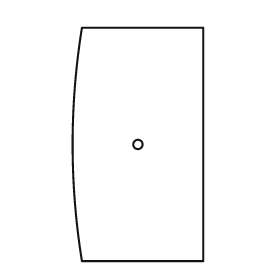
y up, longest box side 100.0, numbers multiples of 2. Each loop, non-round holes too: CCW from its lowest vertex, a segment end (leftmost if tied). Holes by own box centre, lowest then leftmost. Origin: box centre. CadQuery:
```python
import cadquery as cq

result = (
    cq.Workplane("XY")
    .moveTo(-24.0, -50.0)
    .lineTo(28.0, -50.0)
    .lineTo(28.0, 50.0)
    .lineTo(-24.0, 50.0)
    .threePointArc((-28.0, 0.0), (-24.0, -50.0))
    .close()
    .moveTo(0.0, 0.0)
    .circle(2.0)
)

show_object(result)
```